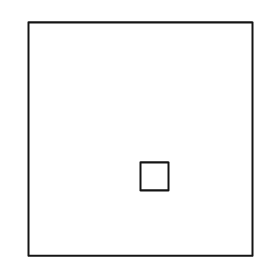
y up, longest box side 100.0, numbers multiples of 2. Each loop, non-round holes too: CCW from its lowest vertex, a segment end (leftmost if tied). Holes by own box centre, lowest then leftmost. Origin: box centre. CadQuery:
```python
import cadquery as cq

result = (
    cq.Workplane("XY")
    .moveTo(-48.0, -50.0)
    .lineTo(48.0, -50.0)
    .lineTo(48.0, 50.0)
    .lineTo(-48.0, 50.0)
    .close()
    .moveTo(0.0, -22.0)
    .lineTo(12.0, -22.0)
    .lineTo(12.0, -10.0)
    .lineTo(0.0, -10.0)
    .close()
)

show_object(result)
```